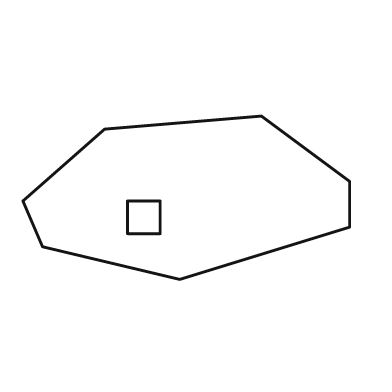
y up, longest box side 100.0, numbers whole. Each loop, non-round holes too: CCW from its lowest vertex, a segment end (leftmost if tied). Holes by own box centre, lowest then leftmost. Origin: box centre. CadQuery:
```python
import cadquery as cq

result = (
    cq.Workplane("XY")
    .moveTo(-2.0, -25.0)
    .lineTo(50.0, -9.0)
    .lineTo(50.0, 5.0)
    .lineTo(23.0, 25.0)
    .lineTo(-25.0, 21.0)
    .lineTo(-50.0, -1.0)
    .lineTo(-44.0, -15.0)
    .close()
    .moveTo(-18.0, -11.0)
    .lineTo(-8.0, -11.0)
    .lineTo(-8.0, -1.0)
    .lineTo(-18.0, -1.0)
    .close()
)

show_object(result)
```